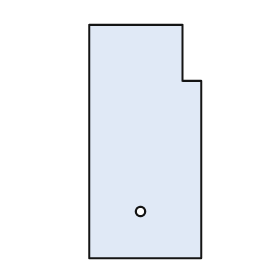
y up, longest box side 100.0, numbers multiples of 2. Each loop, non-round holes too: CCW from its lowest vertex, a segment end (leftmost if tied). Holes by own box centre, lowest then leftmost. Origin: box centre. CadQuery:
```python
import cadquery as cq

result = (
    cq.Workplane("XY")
    .moveTo(-24.0, -50.0)
    .lineTo(24.0, -50.0)
    .lineTo(24.0, 26.0)
    .lineTo(16.0, 26.0)
    .lineTo(16.0, 50.0)
    .lineTo(-24.0, 50.0)
    .close()
    .moveTo(-2.0, -30.0)
    .circle(2.0)
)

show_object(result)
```